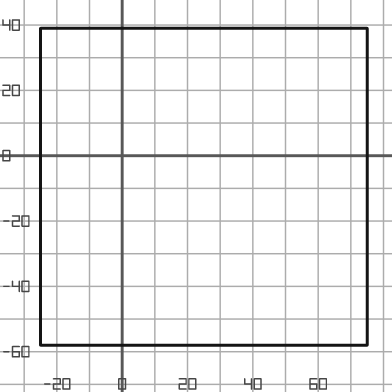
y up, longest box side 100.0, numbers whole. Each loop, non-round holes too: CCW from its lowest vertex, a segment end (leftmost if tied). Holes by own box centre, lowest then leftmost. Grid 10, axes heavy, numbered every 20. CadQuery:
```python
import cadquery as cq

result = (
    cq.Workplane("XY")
    .moveTo(-25.0, -58.0)
    .lineTo(75.0, -58.0)
    .lineTo(75.0, 39.0)
    .lineTo(-25.0, 39.0)
    .close()
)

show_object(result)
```